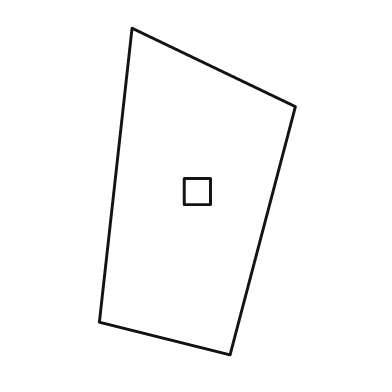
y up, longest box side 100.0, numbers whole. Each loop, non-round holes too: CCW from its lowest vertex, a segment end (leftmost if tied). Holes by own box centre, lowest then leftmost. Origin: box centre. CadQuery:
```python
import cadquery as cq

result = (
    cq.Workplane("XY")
    .moveTo(10.0, -50.0)
    .lineTo(30.0, 26.0)
    .lineTo(-20.0, 50.0)
    .lineTo(-30.0, -40.0)
    .close()
    .moveTo(-4.0, -4.0)
    .lineTo(4.0, -4.0)
    .lineTo(4.0, 4.0)
    .lineTo(-4.0, 4.0)
    .close()
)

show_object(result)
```